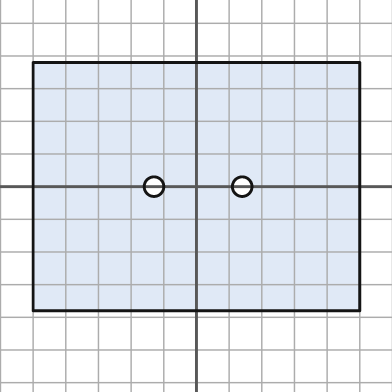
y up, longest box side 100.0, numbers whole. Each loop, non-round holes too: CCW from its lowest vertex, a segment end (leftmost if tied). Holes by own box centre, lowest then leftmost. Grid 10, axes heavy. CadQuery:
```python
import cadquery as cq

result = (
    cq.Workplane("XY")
    .moveTo(-50.0, -38.0)
    .lineTo(50.0, -38.0)
    .lineTo(50.0, 38.0)
    .lineTo(-50.0, 38.0)
    .close()
    .moveTo(-13.0, 0.0)
    .circle(3.0)
    .moveTo(14.0, 0.0)
    .circle(3.0)
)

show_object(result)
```